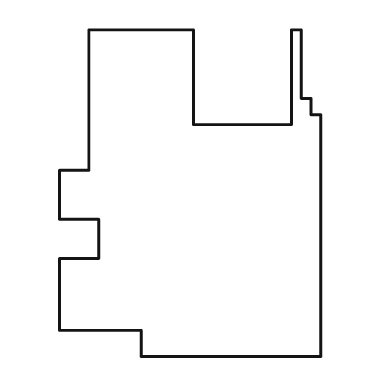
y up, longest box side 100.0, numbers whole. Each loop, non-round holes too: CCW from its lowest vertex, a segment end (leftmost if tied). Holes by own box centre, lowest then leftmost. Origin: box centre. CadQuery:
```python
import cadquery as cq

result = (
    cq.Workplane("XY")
    .moveTo(-15.0, -50.0)
    .lineTo(40.0, -50.0)
    .lineTo(40.0, 24.0)
    .lineTo(37.0, 24.0)
    .lineTo(37.0, 29.0)
    .lineTo(34.0, 29.0)
    .lineTo(34.0, 50.0)
    .lineTo(31.0, 50.0)
    .lineTo(31.0, 21.0)
    .lineTo(1.0, 21.0)
    .lineTo(1.0, 50.0)
    .lineTo(-31.0, 50.0)
    .lineTo(-31.0, 7.0)
    .lineTo(-40.0, 7.0)
    .lineTo(-40.0, -8.0)
    .lineTo(-28.0, -8.0)
    .lineTo(-28.0, -20.0)
    .lineTo(-40.0, -20.0)
    .lineTo(-40.0, -42.0)
    .lineTo(-15.0, -42.0)
    .close()
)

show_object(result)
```